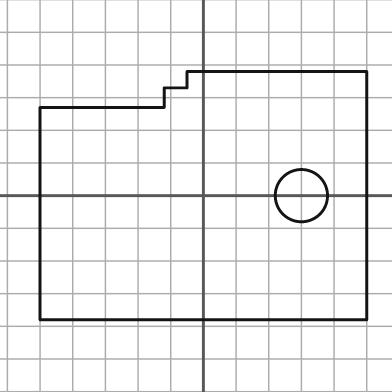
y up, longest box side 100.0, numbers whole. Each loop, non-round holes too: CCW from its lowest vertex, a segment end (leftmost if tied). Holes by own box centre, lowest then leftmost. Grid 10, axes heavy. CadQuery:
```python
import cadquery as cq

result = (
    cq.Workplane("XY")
    .moveTo(-50.0, -38.0)
    .lineTo(50.0, -38.0)
    .lineTo(50.0, 38.0)
    .lineTo(-5.0, 38.0)
    .lineTo(-5.0, 33.0)
    .lineTo(-12.0, 33.0)
    .lineTo(-12.0, 27.0)
    .lineTo(-50.0, 27.0)
    .close()
    .moveTo(30.0, 0.0)
    .circle(8.0)
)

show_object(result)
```